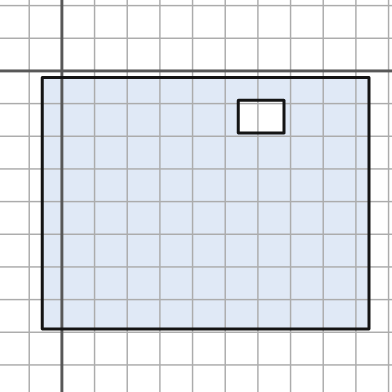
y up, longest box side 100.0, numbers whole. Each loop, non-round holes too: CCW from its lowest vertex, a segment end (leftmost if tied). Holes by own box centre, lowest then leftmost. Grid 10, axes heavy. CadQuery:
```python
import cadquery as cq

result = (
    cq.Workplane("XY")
    .moveTo(-6.0, -79.0)
    .lineTo(94.0, -79.0)
    .lineTo(94.0, -2.0)
    .lineTo(-6.0, -2.0)
    .close()
    .moveTo(54.0, -19.0)
    .lineTo(68.0, -19.0)
    .lineTo(68.0, -9.0)
    .lineTo(54.0, -9.0)
    .close()
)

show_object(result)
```